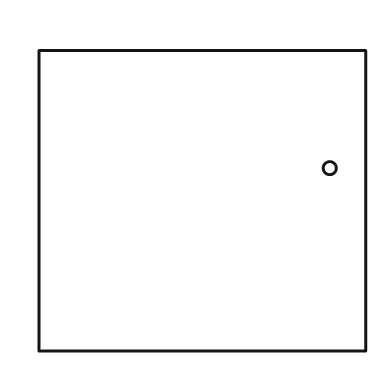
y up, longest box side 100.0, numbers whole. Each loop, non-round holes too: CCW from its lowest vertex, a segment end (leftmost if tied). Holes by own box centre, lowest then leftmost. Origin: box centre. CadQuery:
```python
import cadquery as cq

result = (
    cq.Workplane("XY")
    .moveTo(-50.0, -46.0)
    .lineTo(50.0, -46.0)
    .lineTo(50.0, 46.0)
    .lineTo(-50.0, 46.0)
    .close()
    .moveTo(39.0, 10.0)
    .circle(2.0)
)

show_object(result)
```